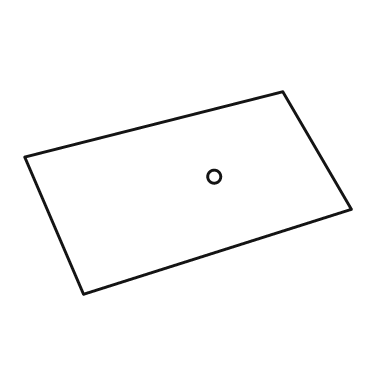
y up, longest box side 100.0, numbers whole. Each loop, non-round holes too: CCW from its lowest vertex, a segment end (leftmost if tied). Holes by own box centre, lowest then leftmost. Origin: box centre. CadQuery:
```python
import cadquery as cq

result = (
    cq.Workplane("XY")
    .moveTo(-32.0, -31.0)
    .lineTo(50.0, -5.0)
    .lineTo(29.0, 31.0)
    .lineTo(-50.0, 11.0)
    .close()
    .moveTo(8.0, 5.0)
    .circle(2.0)
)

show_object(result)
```